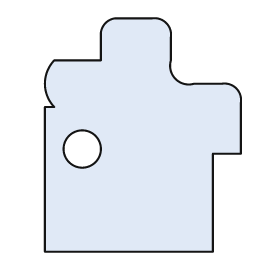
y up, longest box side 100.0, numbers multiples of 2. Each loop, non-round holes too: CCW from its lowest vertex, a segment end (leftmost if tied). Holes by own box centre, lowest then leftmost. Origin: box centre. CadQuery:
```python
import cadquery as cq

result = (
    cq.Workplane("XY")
    .moveTo(-42.0, -50.0)
    .lineTo(30.0, -50.0)
    .lineTo(30.0, -8.0)
    .lineTo(42.0, -8.0)
    .lineTo(42.0, 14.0)
    .threePointArc((40.0, 20.0), (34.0, 22.0))
    .lineTo(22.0, 22.0)
    .threePointArc((14.0, 24.0), (12.0, 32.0))
    .lineTo(12.0, 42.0)
    .threePointArc((10.0, 48.0), (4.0, 50.0))
    .lineTo(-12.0, 50.0)
    .threePointArc((-16.0, 48.0), (-18.0, 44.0))
    .lineTo(-18.0, 32.0)
    .lineTo(-38.0, 32.0)
    .threePointArc((-42.0, 22.0), (-38.0, 12.0))
    .lineTo(-42.0, 12.0)
    .close()
    .moveTo(-26.0, -6.0)
    .circle(8.0)
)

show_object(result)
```